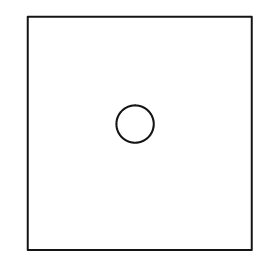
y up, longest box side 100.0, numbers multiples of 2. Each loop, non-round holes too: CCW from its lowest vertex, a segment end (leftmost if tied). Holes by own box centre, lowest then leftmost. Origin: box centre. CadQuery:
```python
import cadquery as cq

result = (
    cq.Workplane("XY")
    .moveTo(-48.0, -50.0)
    .lineTo(48.0, -50.0)
    .lineTo(48.0, 50.0)
    .lineTo(-48.0, 50.0)
    .close()
    .moveTo(-2.0, 4.0)
    .circle(8.0)
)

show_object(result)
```